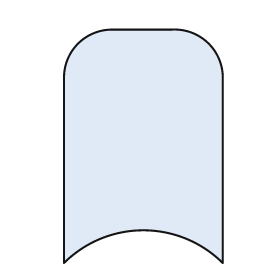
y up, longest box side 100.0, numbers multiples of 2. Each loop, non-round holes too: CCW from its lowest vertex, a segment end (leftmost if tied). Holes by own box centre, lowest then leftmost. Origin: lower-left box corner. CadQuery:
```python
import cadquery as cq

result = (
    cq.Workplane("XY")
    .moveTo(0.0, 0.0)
    .threePointArc((34.0, 14.0), (68.0, 0.0))
    .lineTo(68.0, 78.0)
    .threePointArc((62.0, 94.0), (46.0, 100.0))
    .lineTo(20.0, 100.0)
    .threePointArc((6.0, 94.0), (0.0, 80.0))
    .close()
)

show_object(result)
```